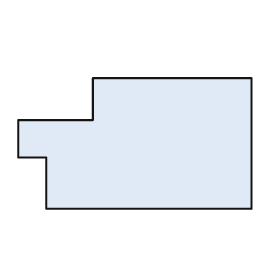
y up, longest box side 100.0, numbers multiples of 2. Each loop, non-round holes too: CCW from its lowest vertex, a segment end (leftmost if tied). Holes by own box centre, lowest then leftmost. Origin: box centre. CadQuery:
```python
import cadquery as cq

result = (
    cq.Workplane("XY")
    .moveTo(-38.0, -28.0)
    .lineTo(50.0, -28.0)
    .lineTo(50.0, 28.0)
    .lineTo(-18.0, 28.0)
    .lineTo(-18.0, 10.0)
    .lineTo(-50.0, 10.0)
    .lineTo(-50.0, -6.0)
    .lineTo(-38.0, -6.0)
    .close()
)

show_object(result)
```